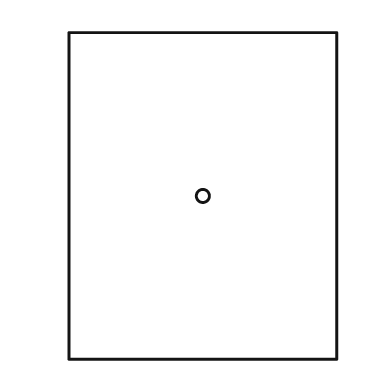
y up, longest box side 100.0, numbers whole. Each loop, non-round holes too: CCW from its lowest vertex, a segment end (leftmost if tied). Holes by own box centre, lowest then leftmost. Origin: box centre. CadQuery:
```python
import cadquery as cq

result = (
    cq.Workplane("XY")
    .moveTo(-41.0, -50.0)
    .lineTo(41.0, -50.0)
    .lineTo(41.0, 50.0)
    .lineTo(-41.0, 50.0)
    .close()
    .moveTo(0.0, 0.0)
    .circle(2.0)
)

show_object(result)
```